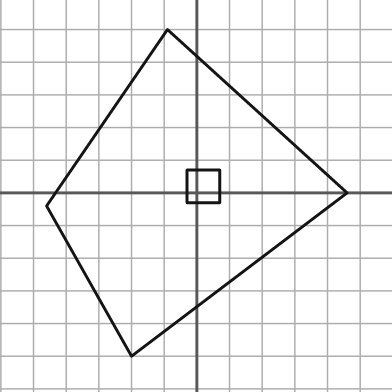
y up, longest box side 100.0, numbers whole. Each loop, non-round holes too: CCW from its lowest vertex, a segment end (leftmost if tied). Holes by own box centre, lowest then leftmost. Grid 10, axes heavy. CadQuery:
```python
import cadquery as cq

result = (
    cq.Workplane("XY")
    .moveTo(-20.0, -50.0)
    .lineTo(46.0, 0.0)
    .lineTo(-9.0, 50.0)
    .lineTo(-46.0, -4.0)
    .close()
    .moveTo(-3.0, -3.0)
    .lineTo(7.0, -3.0)
    .lineTo(7.0, 7.0)
    .lineTo(-3.0, 7.0)
    .close()
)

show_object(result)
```